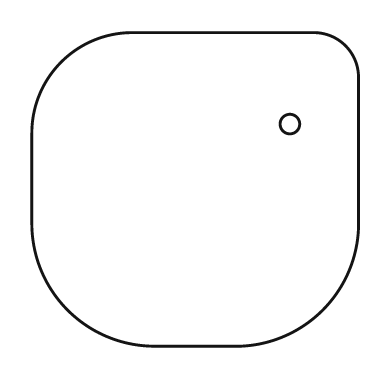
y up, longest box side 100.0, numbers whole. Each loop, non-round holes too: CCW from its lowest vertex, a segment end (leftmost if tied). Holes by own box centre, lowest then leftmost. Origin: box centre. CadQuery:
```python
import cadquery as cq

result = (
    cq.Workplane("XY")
    .moveTo(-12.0, -48.0)
    .lineTo(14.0, -48.0)
    .threePointArc((39.0, -37.0), (50.0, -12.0))
    .lineTo(50.0, 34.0)
    .threePointArc((46.0, 44.0), (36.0, 48.0))
    .lineTo(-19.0, 48.0)
    .threePointArc((-41.0, 39.0), (-50.0, 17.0))
    .lineTo(-50.0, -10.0)
    .threePointArc((-39.0, -37.0), (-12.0, -48.0))
    .close()
    .moveTo(29.0, 20.0)
    .circle(3.0)
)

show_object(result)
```